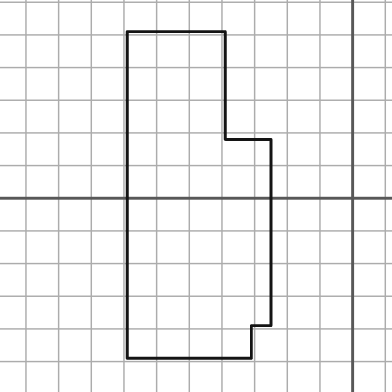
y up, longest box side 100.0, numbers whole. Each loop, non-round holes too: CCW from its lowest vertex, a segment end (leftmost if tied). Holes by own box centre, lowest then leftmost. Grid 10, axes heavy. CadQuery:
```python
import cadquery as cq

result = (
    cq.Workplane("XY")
    .moveTo(-69.0, -49.0)
    .lineTo(-31.0, -49.0)
    .lineTo(-31.0, -39.0)
    .lineTo(-25.0, -39.0)
    .lineTo(-25.0, 18.0)
    .lineTo(-39.0, 18.0)
    .lineTo(-39.0, 51.0)
    .lineTo(-69.0, 51.0)
    .close()
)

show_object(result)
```